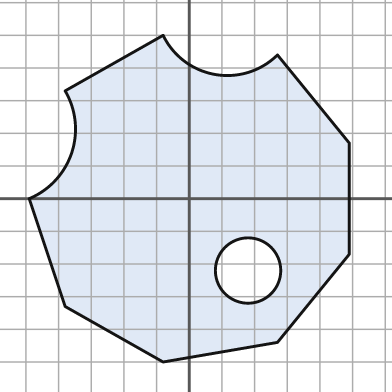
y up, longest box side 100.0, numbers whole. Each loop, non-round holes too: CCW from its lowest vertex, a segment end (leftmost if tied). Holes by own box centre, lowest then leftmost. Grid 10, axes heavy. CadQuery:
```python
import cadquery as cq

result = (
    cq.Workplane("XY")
    .moveTo(-8.0, -50.0)
    .lineTo(27.0, -44.0)
    .lineTo(49.0, -17.0)
    .lineTo(49.0, 17.0)
    .lineTo(27.0, 44.0)
    .threePointArc((8.0, 38.0), (-8.0, 50.0))
    .lineTo(-38.0, 33.0)
    .threePointArc((-36.0, 14.0), (-49.0, 0.0))
    .lineTo(-38.0, -33.0)
    .close()
    .moveTo(18.0, -22.0)
    .circle(10.0)
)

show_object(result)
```